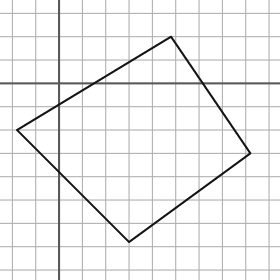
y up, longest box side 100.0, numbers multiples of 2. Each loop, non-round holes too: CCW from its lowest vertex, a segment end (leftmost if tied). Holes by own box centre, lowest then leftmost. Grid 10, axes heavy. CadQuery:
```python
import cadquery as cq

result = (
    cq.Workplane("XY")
    .moveTo(30.0, -68.0)
    .lineTo(82.0, -30.0)
    .lineTo(48.0, 20.0)
    .lineTo(-18.0, -20.0)
    .close()
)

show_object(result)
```